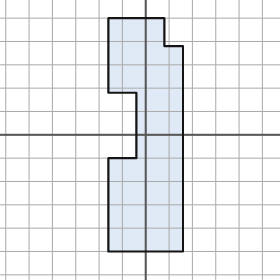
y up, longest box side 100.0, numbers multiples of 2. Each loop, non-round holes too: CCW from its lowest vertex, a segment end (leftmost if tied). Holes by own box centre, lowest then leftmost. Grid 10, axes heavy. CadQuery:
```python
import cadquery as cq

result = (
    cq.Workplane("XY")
    .moveTo(-16.0, -50.0)
    .lineTo(16.0, -50.0)
    .lineTo(16.0, 38.0)
    .lineTo(8.0, 38.0)
    .lineTo(8.0, 50.0)
    .lineTo(-16.0, 50.0)
    .lineTo(-16.0, 18.0)
    .lineTo(-4.0, 18.0)
    .lineTo(-4.0, -10.0)
    .lineTo(-16.0, -10.0)
    .close()
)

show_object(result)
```